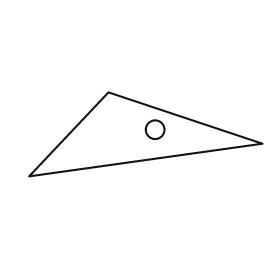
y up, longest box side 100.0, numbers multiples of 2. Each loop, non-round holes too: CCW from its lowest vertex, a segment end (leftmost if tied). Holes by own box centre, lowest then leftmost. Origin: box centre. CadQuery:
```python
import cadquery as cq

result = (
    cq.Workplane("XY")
    .moveTo(-50.0, -18.0)
    .lineTo(50.0, -4.0)
    .lineTo(-16.0, 18.0)
    .close()
    .moveTo(4.0, 2.0)
    .circle(4.0)
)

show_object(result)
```